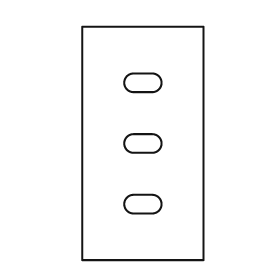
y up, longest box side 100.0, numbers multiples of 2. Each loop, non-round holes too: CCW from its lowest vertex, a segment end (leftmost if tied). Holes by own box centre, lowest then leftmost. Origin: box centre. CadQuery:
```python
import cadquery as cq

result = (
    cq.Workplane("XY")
    .moveTo(-26.0, -50.0)
    .lineTo(26.0, -50.0)
    .lineTo(26.0, 50.0)
    .lineTo(-26.0, 50.0)
    .close()
    .moveTo(-4.0, -30.0)
    .lineTo(4.0, -30.0)
    .threePointArc((8.0, -26.0), (4.0, -22.0))
    .lineTo(-4.0, -22.0)
    .threePointArc((-8.0, -26.0), (-4.0, -30.0))
    .close()
    .moveTo(-4.0, -4.0)
    .lineTo(4.0, -4.0)
    .threePointArc((8.0, 0.0), (4.0, 4.0))
    .lineTo(-4.0, 4.0)
    .threePointArc((-8.0, 0.0), (-4.0, -4.0))
    .close()
    .moveTo(-4.0, 22.0)
    .lineTo(4.0, 22.0)
    .threePointArc((8.0, 26.0), (4.0, 30.0))
    .lineTo(-4.0, 30.0)
    .threePointArc((-8.0, 26.0), (-4.0, 22.0))
    .close()
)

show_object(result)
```